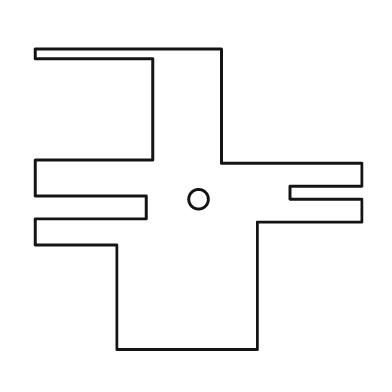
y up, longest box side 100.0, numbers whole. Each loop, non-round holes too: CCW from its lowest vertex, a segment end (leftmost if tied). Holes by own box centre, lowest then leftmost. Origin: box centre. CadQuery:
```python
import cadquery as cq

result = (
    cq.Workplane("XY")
    .moveTo(-25.0, -46.0)
    .lineTo(18.0, -46.0)
    .lineTo(18.0, -7.0)
    .lineTo(50.0, -7.0)
    .lineTo(50.0, 0.0)
    .lineTo(28.0, 0.0)
    .lineTo(28.0, 4.0)
    .lineTo(50.0, 4.0)
    .lineTo(50.0, 11.0)
    .lineTo(7.0, 11.0)
    .lineTo(7.0, 46.0)
    .lineTo(-50.0, 46.0)
    .lineTo(-50.0, 43.0)
    .lineTo(-14.0, 43.0)
    .lineTo(-14.0, 12.0)
    .lineTo(-50.0, 12.0)
    .lineTo(-50.0, 1.0)
    .lineTo(-16.0, 1.0)
    .lineTo(-16.0, -6.0)
    .lineTo(-50.0, -6.0)
    .lineTo(-50.0, -14.0)
    .lineTo(-25.0, -14.0)
    .close()
    .moveTo(0.0, 0.0)
    .circle(3.0)
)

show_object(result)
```